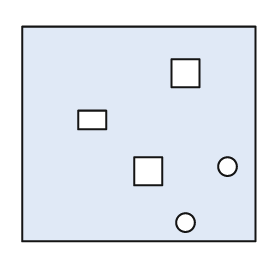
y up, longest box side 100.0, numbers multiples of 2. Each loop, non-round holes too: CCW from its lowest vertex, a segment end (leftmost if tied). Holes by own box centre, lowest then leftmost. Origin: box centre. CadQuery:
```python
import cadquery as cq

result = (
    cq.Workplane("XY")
    .moveTo(-50.0, -46.0)
    .lineTo(50.0, -46.0)
    .lineTo(50.0, 46.0)
    .lineTo(-50.0, 46.0)
    .close()
    .moveTo(20.0, -38.0)
    .circle(4.0)
    .moveTo(-2.0, -22.0)
    .lineTo(10.0, -22.0)
    .lineTo(10.0, -10.0)
    .lineTo(-2.0, -10.0)
    .close()
    .moveTo(38.0, -14.0)
    .circle(4.0)
    .moveTo(-26.0, 2.0)
    .lineTo(-14.0, 2.0)
    .lineTo(-14.0, 10.0)
    .lineTo(-26.0, 10.0)
    .close()
    .moveTo(14.0, 20.0)
    .lineTo(26.0, 20.0)
    .lineTo(26.0, 32.0)
    .lineTo(14.0, 32.0)
    .close()
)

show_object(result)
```